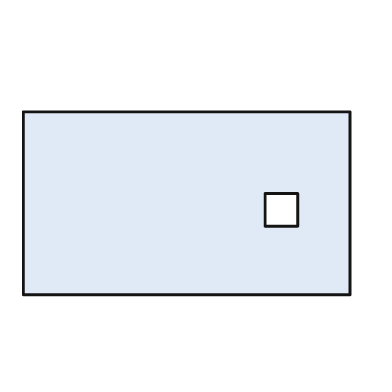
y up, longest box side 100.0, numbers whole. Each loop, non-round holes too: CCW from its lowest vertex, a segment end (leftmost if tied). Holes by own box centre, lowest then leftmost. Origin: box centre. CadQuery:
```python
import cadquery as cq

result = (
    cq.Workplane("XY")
    .moveTo(-50.0, -28.0)
    .lineTo(50.0, -28.0)
    .lineTo(50.0, 28.0)
    .lineTo(-50.0, 28.0)
    .close()
    .moveTo(24.0, -7.0)
    .lineTo(34.0, -7.0)
    .lineTo(34.0, 3.0)
    .lineTo(24.0, 3.0)
    .close()
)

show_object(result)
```